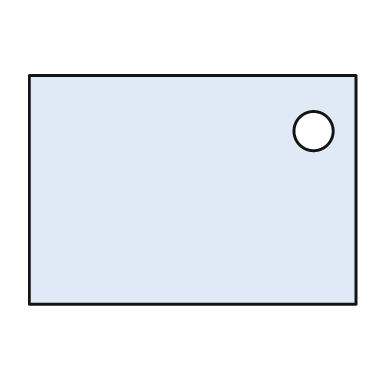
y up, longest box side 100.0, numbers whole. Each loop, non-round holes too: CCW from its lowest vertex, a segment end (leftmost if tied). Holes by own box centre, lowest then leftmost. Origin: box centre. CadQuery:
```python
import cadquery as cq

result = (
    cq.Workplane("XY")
    .moveTo(-50.0, -35.0)
    .lineTo(50.0, -35.0)
    .lineTo(50.0, 35.0)
    .lineTo(-50.0, 35.0)
    .close()
    .moveTo(37.0, 18.0)
    .circle(6.0)
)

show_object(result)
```